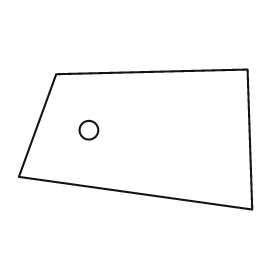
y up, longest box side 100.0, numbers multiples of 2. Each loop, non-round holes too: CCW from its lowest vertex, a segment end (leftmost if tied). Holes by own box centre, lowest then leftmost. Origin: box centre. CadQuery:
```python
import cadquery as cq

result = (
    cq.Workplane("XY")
    .moveTo(50.0, -30.0)
    .lineTo(48.0, 30.0)
    .lineTo(-34.0, 28.0)
    .lineTo(-50.0, -16.0)
    .close()
    .moveTo(-20.0, 4.0)
    .circle(4.0)
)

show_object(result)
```